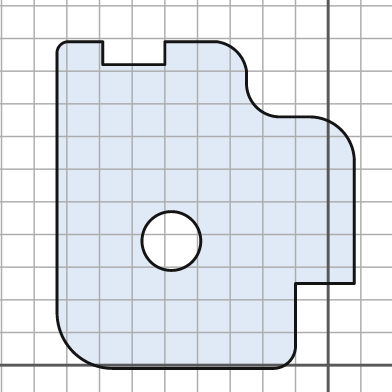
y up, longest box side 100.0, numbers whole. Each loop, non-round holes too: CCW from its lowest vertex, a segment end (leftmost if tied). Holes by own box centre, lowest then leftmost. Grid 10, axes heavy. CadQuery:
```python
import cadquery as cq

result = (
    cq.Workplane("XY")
    .moveTo(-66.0, -1.0)
    .lineTo(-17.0, -1.0)
    .threePointArc((-12.0, 1.0), (-10.0, 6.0))
    .lineTo(-10.0, 25.0)
    .lineTo(8.0, 25.0)
    .lineTo(8.0, 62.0)
    .threePointArc((4.0, 72.0), (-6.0, 76.0))
    .lineTo(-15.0, 76.0)
    .threePointArc((-22.0, 79.0), (-25.0, 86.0))
    .lineTo(-25.0, 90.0)
    .threePointArc((-28.0, 96.0), (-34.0, 99.0))
    .lineTo(-50.0, 99.0)
    .lineTo(-50.0, 92.0)
    .lineTo(-69.0, 92.0)
    .lineTo(-69.0, 99.0)
    .lineTo(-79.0, 99.0)
    .threePointArc((-82.0, 98.0), (-83.0, 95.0))
    .lineTo(-83.0, 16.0)
    .threePointArc((-78.0, 4.0), (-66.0, -1.0))
    .close()
    .moveTo(-48.0, 38.0)
    .circle(9.0)
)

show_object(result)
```